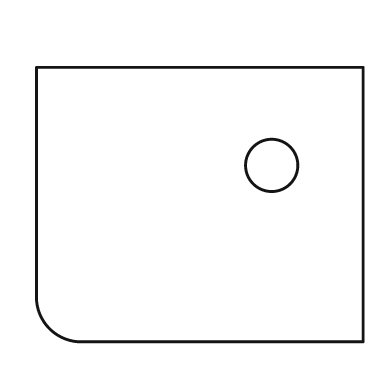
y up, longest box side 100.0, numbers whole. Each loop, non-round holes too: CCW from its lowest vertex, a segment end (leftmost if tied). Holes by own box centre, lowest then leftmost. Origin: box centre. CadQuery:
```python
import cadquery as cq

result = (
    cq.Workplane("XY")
    .moveTo(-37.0, -42.0)
    .lineTo(50.0, -42.0)
    .lineTo(50.0, 42.0)
    .lineTo(-50.0, 42.0)
    .lineTo(-50.0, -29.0)
    .threePointArc((-46.0, -38.0), (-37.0, -42.0))
    .close()
    .moveTo(22.0, 12.0)
    .circle(8.0)
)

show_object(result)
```